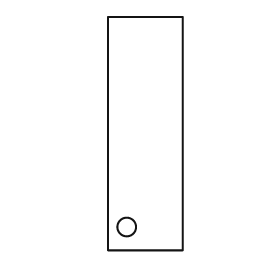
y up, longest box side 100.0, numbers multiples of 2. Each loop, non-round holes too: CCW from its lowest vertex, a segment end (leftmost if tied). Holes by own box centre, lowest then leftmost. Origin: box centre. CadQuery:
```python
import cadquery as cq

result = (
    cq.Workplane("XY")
    .moveTo(-16.0, -50.0)
    .lineTo(16.0, -50.0)
    .lineTo(16.0, 50.0)
    .lineTo(-16.0, 50.0)
    .close()
    .moveTo(-8.0, -40.0)
    .circle(4.0)
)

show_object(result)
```